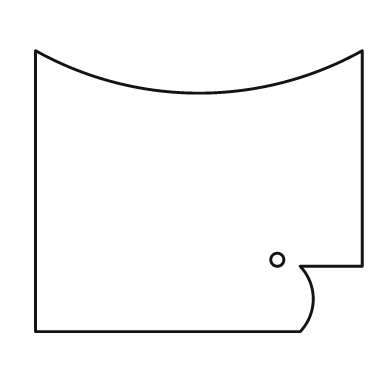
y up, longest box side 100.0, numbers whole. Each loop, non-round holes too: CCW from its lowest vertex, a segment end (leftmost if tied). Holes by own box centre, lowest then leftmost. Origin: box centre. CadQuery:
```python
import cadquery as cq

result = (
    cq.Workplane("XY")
    .moveTo(-50.0, -43.0)
    .lineTo(31.0, -43.0)
    .threePointArc((35.0, -33.0), (31.0, -23.0))
    .lineTo(50.0, -23.0)
    .lineTo(50.0, 43.0)
    .threePointArc((0.0, 30.0), (-50.0, 43.0))
    .close()
    .moveTo(24.0, -21.0)
    .circle(2.0)
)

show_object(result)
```